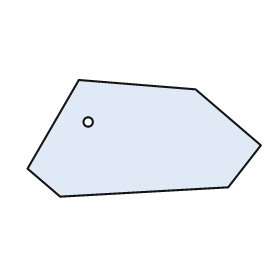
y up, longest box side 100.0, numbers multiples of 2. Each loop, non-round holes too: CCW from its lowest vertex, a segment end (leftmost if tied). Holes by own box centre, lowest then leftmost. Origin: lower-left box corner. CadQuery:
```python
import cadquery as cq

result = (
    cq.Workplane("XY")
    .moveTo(14.0, 0.0)
    .lineTo(86.0, 4.0)
    .lineTo(100.0, 22.0)
    .lineTo(72.0, 46.0)
    .lineTo(22.0, 50.0)
    .lineTo(0.0, 12.0)
    .close()
    .moveTo(26.0, 32.0)
    .circle(2.0)
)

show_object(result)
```